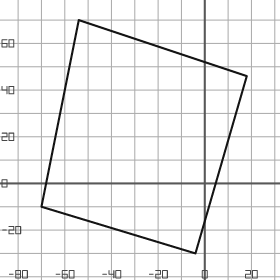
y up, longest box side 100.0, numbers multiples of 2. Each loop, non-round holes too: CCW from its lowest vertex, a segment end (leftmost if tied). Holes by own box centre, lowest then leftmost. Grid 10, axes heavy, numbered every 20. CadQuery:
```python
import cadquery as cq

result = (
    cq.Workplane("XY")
    .moveTo(-4.0, -30.0)
    .lineTo(18.0, 46.0)
    .lineTo(-54.0, 70.0)
    .lineTo(-70.0, -10.0)
    .close()
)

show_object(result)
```